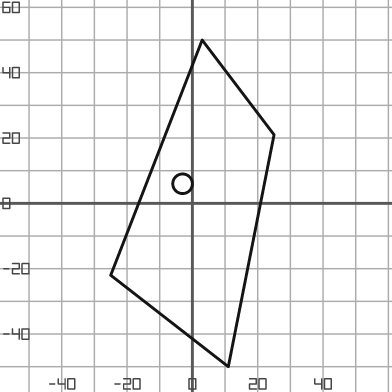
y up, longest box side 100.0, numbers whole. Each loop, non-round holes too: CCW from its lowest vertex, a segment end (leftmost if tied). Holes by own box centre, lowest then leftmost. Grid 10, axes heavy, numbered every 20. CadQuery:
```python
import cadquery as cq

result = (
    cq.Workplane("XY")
    .moveTo(11.0, -50.0)
    .lineTo(25.0, 21.0)
    .lineTo(3.0, 50.0)
    .lineTo(-25.0, -22.0)
    .close()
    .moveTo(-3.0, 6.0)
    .circle(3.0)
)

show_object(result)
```